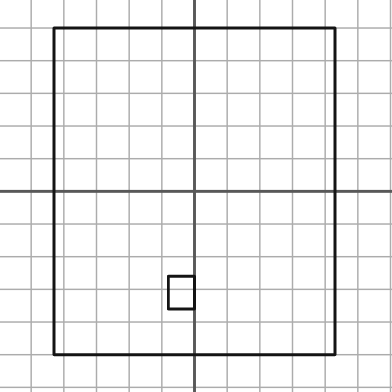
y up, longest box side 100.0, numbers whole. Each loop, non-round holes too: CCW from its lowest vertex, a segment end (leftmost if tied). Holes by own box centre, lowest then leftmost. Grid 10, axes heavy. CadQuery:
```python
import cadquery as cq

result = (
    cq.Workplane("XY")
    .moveTo(-43.0, -50.0)
    .lineTo(43.0, -50.0)
    .lineTo(43.0, 50.0)
    .lineTo(-43.0, 50.0)
    .close()
    .moveTo(-8.0, -36.0)
    .lineTo(0.0, -36.0)
    .lineTo(0.0, -26.0)
    .lineTo(-8.0, -26.0)
    .close()
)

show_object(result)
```